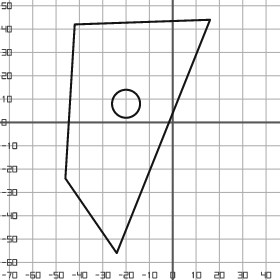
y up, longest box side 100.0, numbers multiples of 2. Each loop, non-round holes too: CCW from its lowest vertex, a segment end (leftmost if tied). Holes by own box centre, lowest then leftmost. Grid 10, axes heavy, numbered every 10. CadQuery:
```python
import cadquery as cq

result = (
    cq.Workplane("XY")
    .moveTo(-24.0, -56.0)
    .lineTo(16.0, 44.0)
    .lineTo(-42.0, 42.0)
    .lineTo(-46.0, -24.0)
    .close()
    .moveTo(-20.0, 8.0)
    .circle(6.0)
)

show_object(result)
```